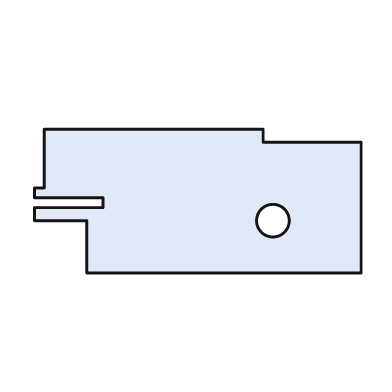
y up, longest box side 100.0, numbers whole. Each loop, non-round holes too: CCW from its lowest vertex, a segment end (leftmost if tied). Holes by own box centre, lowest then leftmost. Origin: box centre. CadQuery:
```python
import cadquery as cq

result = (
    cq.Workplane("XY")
    .moveTo(-34.0, -22.0)
    .lineTo(50.0, -22.0)
    .lineTo(50.0, 18.0)
    .lineTo(20.0, 18.0)
    .lineTo(20.0, 22.0)
    .lineTo(-47.0, 22.0)
    .lineTo(-47.0, 4.0)
    .lineTo(-50.0, 4.0)
    .lineTo(-50.0, 1.0)
    .lineTo(-29.0, 1.0)
    .lineTo(-29.0, -2.0)
    .lineTo(-50.0, -2.0)
    .lineTo(-50.0, -6.0)
    .lineTo(-34.0, -6.0)
    .close()
    .moveTo(23.0, -6.0)
    .circle(5.0)
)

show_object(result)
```